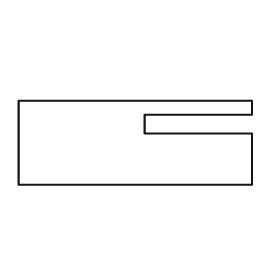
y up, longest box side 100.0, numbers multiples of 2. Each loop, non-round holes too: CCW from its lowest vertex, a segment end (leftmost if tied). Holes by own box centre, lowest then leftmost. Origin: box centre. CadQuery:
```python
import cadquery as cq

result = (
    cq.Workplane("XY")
    .moveTo(-50.0, -18.0)
    .lineTo(50.0, -18.0)
    .lineTo(50.0, 4.0)
    .lineTo(4.0, 4.0)
    .lineTo(4.0, 12.0)
    .lineTo(50.0, 12.0)
    .lineTo(50.0, 18.0)
    .lineTo(-50.0, 18.0)
    .close()
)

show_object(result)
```